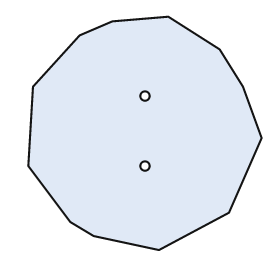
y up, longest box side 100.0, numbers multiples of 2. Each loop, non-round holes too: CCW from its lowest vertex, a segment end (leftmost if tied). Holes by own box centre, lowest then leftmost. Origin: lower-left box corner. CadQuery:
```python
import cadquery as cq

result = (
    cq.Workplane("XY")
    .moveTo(56.0, 0.0)
    .lineTo(86.0, 16.0)
    .lineTo(100.0, 48.0)
    .lineTo(92.0, 70.0)
    .lineTo(82.0, 86.0)
    .lineTo(60.0, 100.0)
    .lineTo(36.0, 98.0)
    .lineTo(22.0, 92.0)
    .lineTo(2.0, 70.0)
    .lineTo(0.0, 36.0)
    .lineTo(18.0, 12.0)
    .lineTo(28.0, 6.0)
    .close()
    .moveTo(50.0, 36.0)
    .circle(2.0)
    .moveTo(50.0, 66.0)
    .circle(2.0)
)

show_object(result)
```